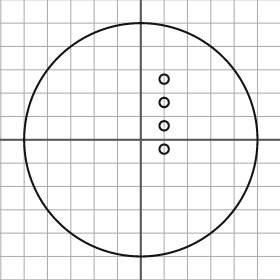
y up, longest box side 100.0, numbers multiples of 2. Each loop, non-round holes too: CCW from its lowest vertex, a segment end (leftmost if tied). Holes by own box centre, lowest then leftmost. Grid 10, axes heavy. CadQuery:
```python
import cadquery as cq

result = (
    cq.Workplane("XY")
    .moveTo(0.0, 0.0)
    .circle(50.0)
    .moveTo(10.0, -4.0)
    .circle(2.0)
    .moveTo(10.0, 6.0)
    .circle(2.0)
    .moveTo(10.0, 16.0)
    .circle(2.0)
    .moveTo(10.0, 26.0)
    .circle(2.0)
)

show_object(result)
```